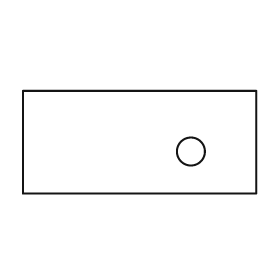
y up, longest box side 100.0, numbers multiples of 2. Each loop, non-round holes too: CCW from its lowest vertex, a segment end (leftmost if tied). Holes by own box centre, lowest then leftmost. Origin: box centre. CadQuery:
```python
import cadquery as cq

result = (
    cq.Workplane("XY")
    .moveTo(-50.0, -22.0)
    .lineTo(50.0, -22.0)
    .lineTo(50.0, 22.0)
    .lineTo(-50.0, 22.0)
    .close()
    .moveTo(22.0, -4.0)
    .circle(6.0)
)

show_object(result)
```